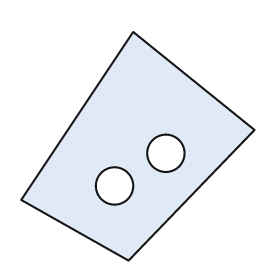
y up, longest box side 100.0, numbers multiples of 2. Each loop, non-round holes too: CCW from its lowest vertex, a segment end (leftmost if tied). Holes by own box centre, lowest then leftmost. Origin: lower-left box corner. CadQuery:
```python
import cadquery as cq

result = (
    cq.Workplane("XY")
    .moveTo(46.0, 0.0)
    .lineTo(100.0, 56.0)
    .lineTo(48.0, 98.0)
    .lineTo(0.0, 26.0)
    .close()
    .moveTo(40.0, 32.0)
    .circle(8.0)
    .moveTo(62.0, 46.0)
    .circle(8.0)
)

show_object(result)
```